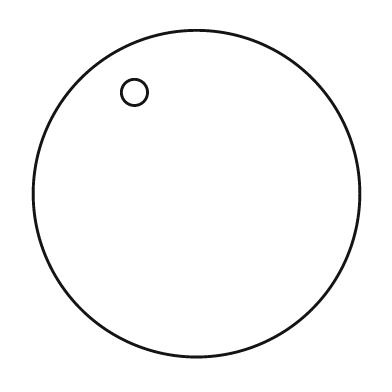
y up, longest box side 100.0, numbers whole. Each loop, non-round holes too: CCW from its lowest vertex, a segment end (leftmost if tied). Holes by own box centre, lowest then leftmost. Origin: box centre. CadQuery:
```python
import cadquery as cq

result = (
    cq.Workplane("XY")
    .moveTo(0.0, 0.0)
    .circle(50.0)
    .moveTo(-19.0, 31.0)
    .circle(4.0)
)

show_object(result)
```